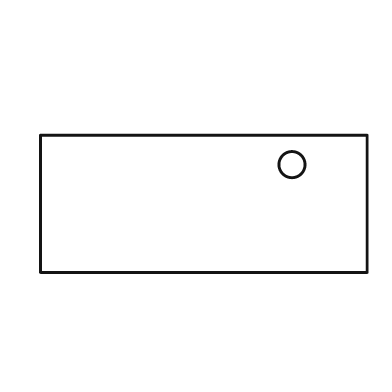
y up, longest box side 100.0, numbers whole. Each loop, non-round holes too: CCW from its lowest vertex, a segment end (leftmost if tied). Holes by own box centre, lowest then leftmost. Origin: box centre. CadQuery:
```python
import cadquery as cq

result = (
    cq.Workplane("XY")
    .moveTo(-50.0, -21.0)
    .lineTo(50.0, -21.0)
    .lineTo(50.0, 21.0)
    .lineTo(-50.0, 21.0)
    .close()
    .moveTo(27.0, 12.0)
    .circle(4.0)
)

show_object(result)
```